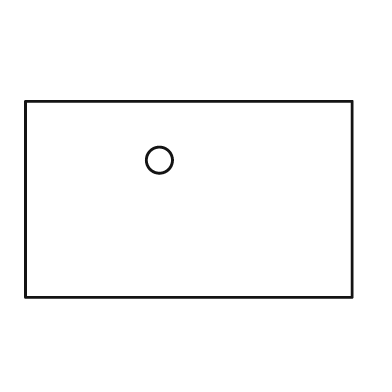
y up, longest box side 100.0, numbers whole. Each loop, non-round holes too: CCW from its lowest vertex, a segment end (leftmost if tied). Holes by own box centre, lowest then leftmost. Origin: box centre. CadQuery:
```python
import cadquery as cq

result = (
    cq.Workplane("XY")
    .moveTo(-50.0, -30.0)
    .lineTo(50.0, -30.0)
    .lineTo(50.0, 30.0)
    .lineTo(-50.0, 30.0)
    .close()
    .moveTo(-9.0, 12.0)
    .circle(4.0)
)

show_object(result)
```